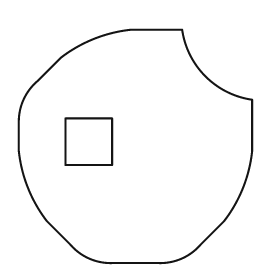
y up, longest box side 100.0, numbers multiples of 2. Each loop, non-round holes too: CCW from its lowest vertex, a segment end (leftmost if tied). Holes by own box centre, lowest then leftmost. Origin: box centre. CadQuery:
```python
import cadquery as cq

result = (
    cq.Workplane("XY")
    .moveTo(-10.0, -50.0)
    .lineTo(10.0, -50.0)
    .threePointArc((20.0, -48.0), (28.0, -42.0))
    .lineTo(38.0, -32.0)
    .threePointArc((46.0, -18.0), (50.0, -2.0))
    .lineTo(50.0, 20.0)
    .threePointArc((30.0, 30.0), (20.0, 50.0))
    .lineTo(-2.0, 50.0)
    .threePointArc((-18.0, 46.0), (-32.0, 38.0))
    .lineTo(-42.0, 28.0)
    .threePointArc((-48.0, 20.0), (-50.0, 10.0))
    .lineTo(-50.0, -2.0)
    .threePointArc((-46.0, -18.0), (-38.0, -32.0))
    .lineTo(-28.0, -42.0)
    .threePointArc((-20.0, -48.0), (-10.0, -50.0))
    .close()
    .moveTo(-30.0, -8.0)
    .lineTo(-10.0, -8.0)
    .lineTo(-10.0, 12.0)
    .lineTo(-30.0, 12.0)
    .close()
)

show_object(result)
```